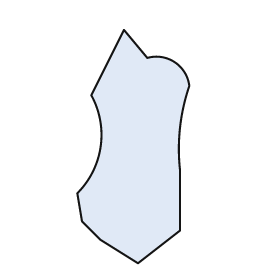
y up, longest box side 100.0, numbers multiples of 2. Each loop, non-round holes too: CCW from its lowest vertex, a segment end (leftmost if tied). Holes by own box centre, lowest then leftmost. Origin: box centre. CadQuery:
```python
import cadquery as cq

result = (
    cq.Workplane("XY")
    .moveTo(2.0, -50.0)
    .lineTo(20.0, -36.0)
    .lineTo(20.0, -10.0)
    .threePointArc((20.0, 8.0), (24.0, 26.0))
    .threePointArc((18.0, 36.0), (6.0, 38.0))
    .lineTo(-4.0, 50.0)
    .lineTo(-18.0, 22.0)
    .threePointArc((-14.0, 0.0), (-24.0, -20.0))
    .lineTo(-22.0, -32.0)
    .lineTo(-14.0, -40.0)
    .close()
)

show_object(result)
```